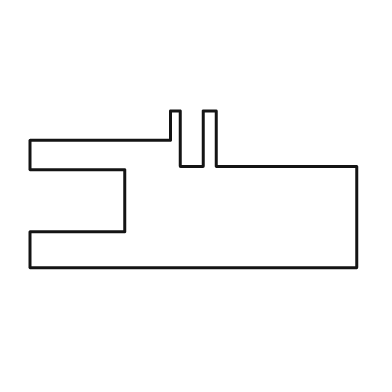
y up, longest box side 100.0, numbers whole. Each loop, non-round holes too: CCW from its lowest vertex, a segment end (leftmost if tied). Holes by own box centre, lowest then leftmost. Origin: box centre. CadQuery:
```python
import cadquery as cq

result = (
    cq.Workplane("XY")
    .moveTo(-50.0, -24.0)
    .lineTo(50.0, -24.0)
    .lineTo(50.0, 7.0)
    .lineTo(7.0, 7.0)
    .lineTo(7.0, 24.0)
    .lineTo(3.0, 24.0)
    .lineTo(3.0, 7.0)
    .lineTo(-4.0, 7.0)
    .lineTo(-4.0, 24.0)
    .lineTo(-7.0, 24.0)
    .lineTo(-7.0, 15.0)
    .lineTo(-50.0, 15.0)
    .lineTo(-50.0, 6.0)
    .lineTo(-21.0, 6.0)
    .lineTo(-21.0, -13.0)
    .lineTo(-50.0, -13.0)
    .close()
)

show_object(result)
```